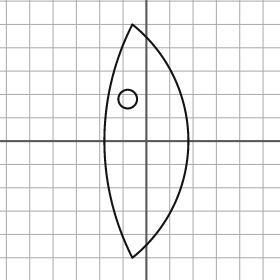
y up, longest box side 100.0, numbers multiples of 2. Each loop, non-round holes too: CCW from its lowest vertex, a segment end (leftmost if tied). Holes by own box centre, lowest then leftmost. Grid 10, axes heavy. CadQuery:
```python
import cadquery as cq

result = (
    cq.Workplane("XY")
    .moveTo(-6.0, -50.0)
    .threePointArc((18.0, 0.0), (-6.0, 50.0))
    .threePointArc((-18.0, 0.0), (-6.0, -50.0))
    .close()
    .moveTo(-8.0, 18.0)
    .circle(4.0)
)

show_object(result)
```